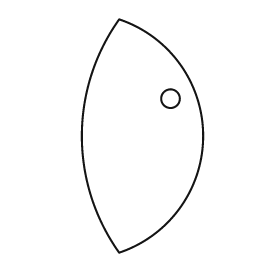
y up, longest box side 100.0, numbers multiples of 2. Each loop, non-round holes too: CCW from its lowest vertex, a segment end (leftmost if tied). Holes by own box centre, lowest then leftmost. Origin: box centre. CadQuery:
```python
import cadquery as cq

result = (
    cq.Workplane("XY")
    .moveTo(-10.0, -50.0)
    .threePointArc((26.0, 0.0), (-10.0, 50.0))
    .threePointArc((-26.0, 0.0), (-10.0, -50.0))
    .close()
    .moveTo(12.0, 16.0)
    .circle(4.0)
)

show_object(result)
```